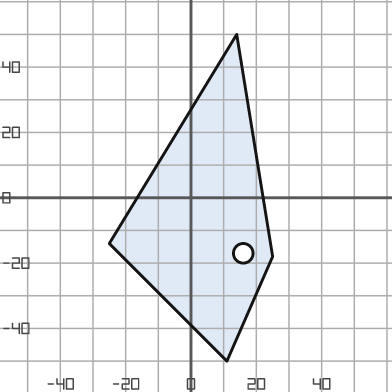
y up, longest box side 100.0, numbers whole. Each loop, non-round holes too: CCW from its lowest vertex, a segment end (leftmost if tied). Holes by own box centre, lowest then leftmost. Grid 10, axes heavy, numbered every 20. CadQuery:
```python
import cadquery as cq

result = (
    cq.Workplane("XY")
    .moveTo(11.0, -50.0)
    .lineTo(25.0, -18.0)
    .lineTo(14.0, 50.0)
    .lineTo(-25.0, -14.0)
    .close()
    .moveTo(16.0, -17.0)
    .circle(3.0)
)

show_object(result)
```